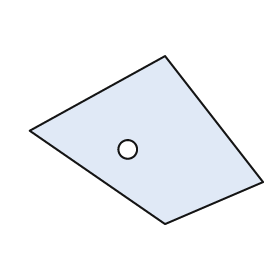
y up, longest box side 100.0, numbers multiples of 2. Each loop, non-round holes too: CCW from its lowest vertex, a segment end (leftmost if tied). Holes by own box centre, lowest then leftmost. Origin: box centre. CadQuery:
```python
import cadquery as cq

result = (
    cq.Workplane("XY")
    .moveTo(8.0, -36.0)
    .lineTo(50.0, -18.0)
    .lineTo(8.0, 36.0)
    .lineTo(-50.0, 4.0)
    .close()
    .moveTo(-8.0, -4.0)
    .circle(4.0)
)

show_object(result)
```